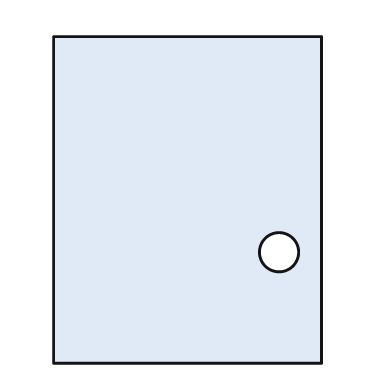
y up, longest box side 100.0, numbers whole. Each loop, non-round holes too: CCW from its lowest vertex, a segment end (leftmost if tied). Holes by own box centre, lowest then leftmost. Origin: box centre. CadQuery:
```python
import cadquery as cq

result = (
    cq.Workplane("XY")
    .moveTo(-41.0, -50.0)
    .lineTo(41.0, -50.0)
    .lineTo(41.0, 50.0)
    .lineTo(-41.0, 50.0)
    .close()
    .moveTo(28.0, -16.0)
    .circle(6.0)
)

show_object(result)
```